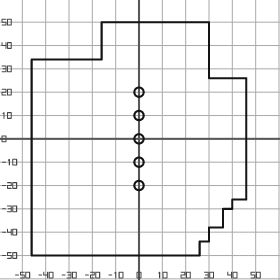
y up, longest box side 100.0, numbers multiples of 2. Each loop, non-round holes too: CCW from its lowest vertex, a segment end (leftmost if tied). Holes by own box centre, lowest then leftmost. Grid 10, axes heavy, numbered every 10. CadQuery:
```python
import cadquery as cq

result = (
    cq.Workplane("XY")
    .moveTo(-46.0, -50.0)
    .lineTo(26.0, -50.0)
    .lineTo(26.0, -44.0)
    .lineTo(30.0, -44.0)
    .lineTo(30.0, -38.0)
    .lineTo(36.0, -38.0)
    .lineTo(36.0, -30.0)
    .lineTo(40.0, -30.0)
    .lineTo(40.0, -26.0)
    .lineTo(46.0, -26.0)
    .lineTo(46.0, 26.0)
    .lineTo(30.0, 26.0)
    .lineTo(30.0, 50.0)
    .lineTo(-16.0, 50.0)
    .lineTo(-16.0, 34.0)
    .lineTo(-46.0, 34.0)
    .close()
    .moveTo(0.0, -20.0)
    .circle(2.0)
    .moveTo(0.0, -10.0)
    .circle(2.0)
    .moveTo(0.0, 0.0)
    .circle(2.0)
    .moveTo(0.0, 10.0)
    .circle(2.0)
    .moveTo(0.0, 20.0)
    .circle(2.0)
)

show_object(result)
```